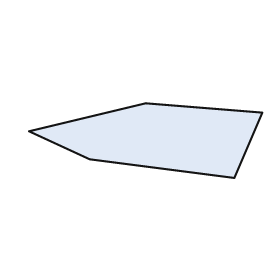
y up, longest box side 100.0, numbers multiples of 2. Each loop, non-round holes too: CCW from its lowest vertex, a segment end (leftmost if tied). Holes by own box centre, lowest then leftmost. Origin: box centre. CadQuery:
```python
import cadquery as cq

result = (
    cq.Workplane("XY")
    .moveTo(38.0, -16.0)
    .lineTo(50.0, 12.0)
    .lineTo(0.0, 16.0)
    .lineTo(-50.0, 4.0)
    .lineTo(-24.0, -8.0)
    .close()
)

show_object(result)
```